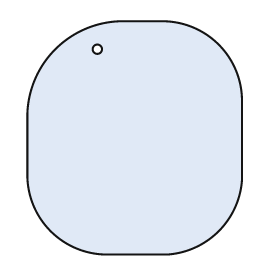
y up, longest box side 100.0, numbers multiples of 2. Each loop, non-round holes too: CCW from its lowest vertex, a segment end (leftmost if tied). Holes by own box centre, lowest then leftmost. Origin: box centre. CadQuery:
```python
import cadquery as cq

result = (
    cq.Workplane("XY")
    .moveTo(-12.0, -50.0)
    .lineTo(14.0, -50.0)
    .threePointArc((36.0, -40.0), (46.0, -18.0))
    .lineTo(46.0, 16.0)
    .threePointArc((36.0, 40.0), (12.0, 50.0))
    .lineTo(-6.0, 50.0)
    .threePointArc((-34.0, 38.0), (-46.0, 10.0))
    .lineTo(-46.0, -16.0)
    .threePointArc((-36.0, -40.0), (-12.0, -50.0))
    .close()
    .moveTo(-16.0, 38.0)
    .circle(2.0)
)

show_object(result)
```